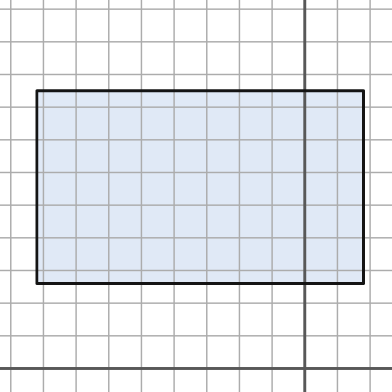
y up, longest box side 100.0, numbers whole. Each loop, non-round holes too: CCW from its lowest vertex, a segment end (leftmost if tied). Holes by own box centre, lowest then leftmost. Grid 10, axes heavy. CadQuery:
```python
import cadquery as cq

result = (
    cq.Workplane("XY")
    .moveTo(-82.0, 26.0)
    .lineTo(18.0, 26.0)
    .lineTo(18.0, 85.0)
    .lineTo(-82.0, 85.0)
    .close()
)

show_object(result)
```